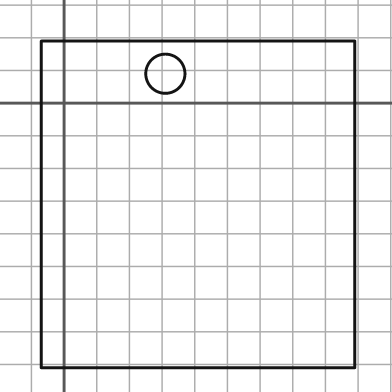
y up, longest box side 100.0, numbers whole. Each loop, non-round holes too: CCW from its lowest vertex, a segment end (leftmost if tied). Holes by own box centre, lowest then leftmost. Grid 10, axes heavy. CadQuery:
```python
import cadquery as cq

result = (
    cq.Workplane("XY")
    .moveTo(-7.0, -81.0)
    .lineTo(89.0, -81.0)
    .lineTo(89.0, 19.0)
    .lineTo(-7.0, 19.0)
    .close()
    .moveTo(31.0, 9.0)
    .circle(6.0)
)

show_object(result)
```